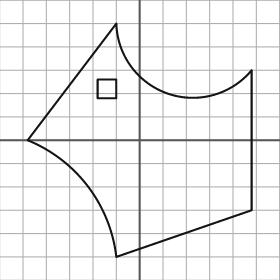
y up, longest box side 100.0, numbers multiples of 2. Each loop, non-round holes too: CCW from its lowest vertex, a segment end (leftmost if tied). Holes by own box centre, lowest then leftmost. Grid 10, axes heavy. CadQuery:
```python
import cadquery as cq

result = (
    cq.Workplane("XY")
    .moveTo(-10.0, -50.0)
    .lineTo(48.0, -30.0)
    .lineTo(48.0, 30.0)
    .threePointArc((12.0, 20.0), (-10.0, 50.0))
    .lineTo(-48.0, 0.0)
    .threePointArc((-22.0, -20.0), (-10.0, -50.0))
    .close()
    .moveTo(-18.0, 18.0)
    .lineTo(-10.0, 18.0)
    .lineTo(-10.0, 26.0)
    .lineTo(-18.0, 26.0)
    .close()
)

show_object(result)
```